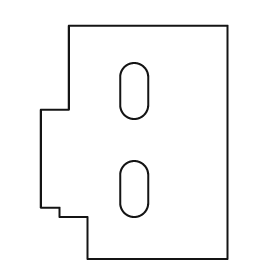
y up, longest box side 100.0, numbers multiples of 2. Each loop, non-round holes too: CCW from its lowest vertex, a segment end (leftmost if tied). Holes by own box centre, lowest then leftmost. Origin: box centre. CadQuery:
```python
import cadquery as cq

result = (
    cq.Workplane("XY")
    .moveTo(-20.0, -50.0)
    .lineTo(40.0, -50.0)
    .lineTo(40.0, 50.0)
    .lineTo(-28.0, 50.0)
    .lineTo(-28.0, 14.0)
    .lineTo(-40.0, 14.0)
    .lineTo(-40.0, -28.0)
    .lineTo(-32.0, -28.0)
    .lineTo(-32.0, -32.0)
    .lineTo(-20.0, -32.0)
    .close()
    .moveTo(-6.0, -26.0)
    .threePointArc((0.0, -32.0), (6.0, -26.0))
    .lineTo(6.0, -14.0)
    .threePointArc((0.0, -8.0), (-6.0, -14.0))
    .close()
    .moveTo(-6.0, 16.0)
    .threePointArc((0.0, 10.0), (6.0, 16.0))
    .lineTo(6.0, 28.0)
    .threePointArc((0.0, 34.0), (-6.0, 28.0))
    .close()
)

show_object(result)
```